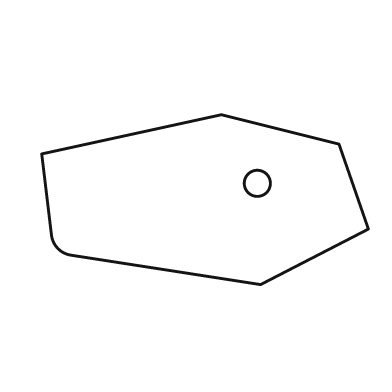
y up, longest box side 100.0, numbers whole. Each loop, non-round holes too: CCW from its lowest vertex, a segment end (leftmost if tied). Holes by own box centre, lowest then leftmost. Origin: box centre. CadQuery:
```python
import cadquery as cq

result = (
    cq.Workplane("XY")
    .moveTo(17.0, -26.0)
    .lineTo(50.0, -9.0)
    .lineTo(41.0, 17.0)
    .lineTo(5.0, 26.0)
    .lineTo(-50.0, 14.0)
    .lineTo(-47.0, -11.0)
    .threePointArc((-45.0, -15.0), (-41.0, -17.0))
    .close()
    .moveTo(16.0, 5.0)
    .circle(4.0)
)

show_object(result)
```